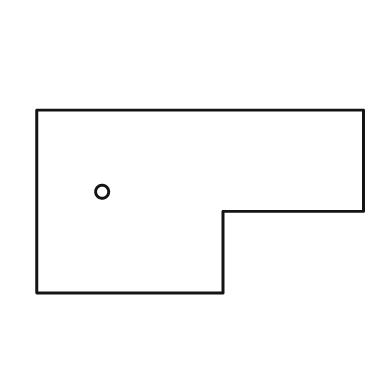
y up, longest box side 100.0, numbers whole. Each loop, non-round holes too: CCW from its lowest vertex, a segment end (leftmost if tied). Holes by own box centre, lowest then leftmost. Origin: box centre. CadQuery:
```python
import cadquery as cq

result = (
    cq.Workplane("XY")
    .moveTo(-50.0, -28.0)
    .lineTo(7.0, -28.0)
    .lineTo(7.0, -3.0)
    .lineTo(50.0, -3.0)
    .lineTo(50.0, 28.0)
    .lineTo(-50.0, 28.0)
    .close()
    .moveTo(-30.0, 3.0)
    .circle(2.0)
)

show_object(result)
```